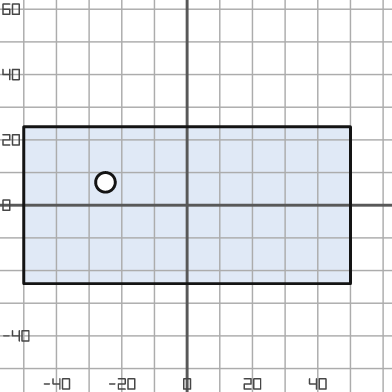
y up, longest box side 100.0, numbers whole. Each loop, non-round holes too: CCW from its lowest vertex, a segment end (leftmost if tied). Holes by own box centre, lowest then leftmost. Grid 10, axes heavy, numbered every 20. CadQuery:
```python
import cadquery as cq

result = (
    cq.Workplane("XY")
    .moveTo(-50.0, -24.0)
    .lineTo(50.0, -24.0)
    .lineTo(50.0, 24.0)
    .lineTo(-50.0, 24.0)
    .close()
    .moveTo(-25.0, 7.0)
    .circle(3.0)
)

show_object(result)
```